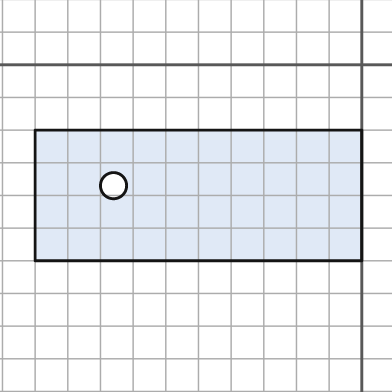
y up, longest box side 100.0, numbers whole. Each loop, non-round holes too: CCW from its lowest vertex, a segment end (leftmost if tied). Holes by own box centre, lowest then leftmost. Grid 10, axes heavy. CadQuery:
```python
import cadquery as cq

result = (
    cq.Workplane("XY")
    .moveTo(-100.0, -60.0)
    .lineTo(0.0, -60.0)
    .lineTo(0.0, -20.0)
    .lineTo(-100.0, -20.0)
    .close()
    .moveTo(-76.0, -37.0)
    .circle(4.0)
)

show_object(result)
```